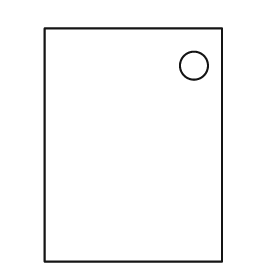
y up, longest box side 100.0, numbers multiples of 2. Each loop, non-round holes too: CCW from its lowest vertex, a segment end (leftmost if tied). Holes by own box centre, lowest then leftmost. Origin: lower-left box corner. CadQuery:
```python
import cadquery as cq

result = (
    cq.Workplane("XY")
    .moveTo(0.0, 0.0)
    .lineTo(76.0, 0.0)
    .lineTo(76.0, 100.0)
    .lineTo(0.0, 100.0)
    .close()
    .moveTo(64.0, 84.0)
    .circle(6.0)
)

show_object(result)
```